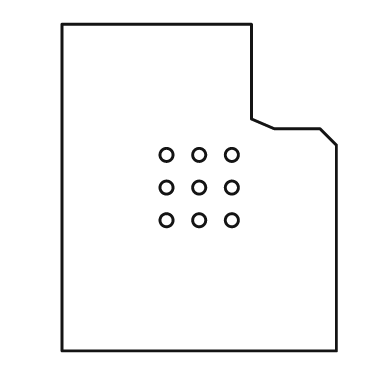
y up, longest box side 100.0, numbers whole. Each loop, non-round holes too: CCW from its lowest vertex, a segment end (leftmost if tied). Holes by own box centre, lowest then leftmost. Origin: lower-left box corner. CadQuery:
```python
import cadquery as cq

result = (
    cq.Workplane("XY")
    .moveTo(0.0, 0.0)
    .lineTo(84.0, 0.0)
    .lineTo(84.0, 63.0)
    .lineTo(79.0, 68.0)
    .lineTo(65.0, 68.0)
    .lineTo(58.0, 71.0)
    .lineTo(58.0, 100.0)
    .lineTo(0.0, 100.0)
    .close()
    .moveTo(32.0, 40.0)
    .circle(2.0)
    .moveTo(42.0, 40.0)
    .circle(2.0)
    .moveTo(52.0, 40.0)
    .circle(2.0)
    .moveTo(32.0, 50.0)
    .circle(2.0)
    .moveTo(42.0, 50.0)
    .circle(2.0)
    .moveTo(52.0, 50.0)
    .circle(2.0)
    .moveTo(32.0, 60.0)
    .circle(2.0)
    .moveTo(42.0, 60.0)
    .circle(2.0)
    .moveTo(52.0, 60.0)
    .circle(2.0)
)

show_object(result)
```